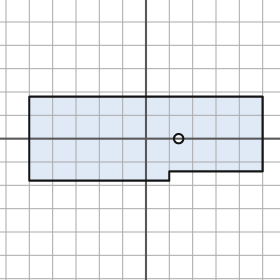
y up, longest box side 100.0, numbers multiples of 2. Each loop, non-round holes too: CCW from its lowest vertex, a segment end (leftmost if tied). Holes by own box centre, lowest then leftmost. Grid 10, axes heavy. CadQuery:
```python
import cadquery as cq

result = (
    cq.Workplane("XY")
    .moveTo(-50.0, -18.0)
    .lineTo(10.0, -18.0)
    .lineTo(10.0, -14.0)
    .lineTo(50.0, -14.0)
    .lineTo(50.0, 18.0)
    .lineTo(-50.0, 18.0)
    .close()
    .moveTo(14.0, 0.0)
    .circle(2.0)
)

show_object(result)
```